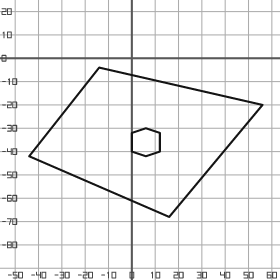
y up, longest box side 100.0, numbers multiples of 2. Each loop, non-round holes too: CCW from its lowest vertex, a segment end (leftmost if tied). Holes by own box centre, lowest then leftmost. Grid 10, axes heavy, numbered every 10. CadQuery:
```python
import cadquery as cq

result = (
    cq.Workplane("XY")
    .moveTo(16.0, -68.0)
    .lineTo(56.0, -20.0)
    .lineTo(-14.0, -4.0)
    .lineTo(-44.0, -42.0)
    .close()
    .moveTo(6.0, -42.0)
    .lineTo(12.0, -40.0)
    .lineTo(12.0, -32.0)
    .lineTo(6.0, -30.0)
    .lineTo(0.0, -32.0)
    .lineTo(0.0, -40.0)
    .close()
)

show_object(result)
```